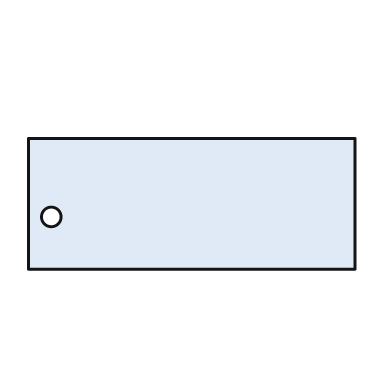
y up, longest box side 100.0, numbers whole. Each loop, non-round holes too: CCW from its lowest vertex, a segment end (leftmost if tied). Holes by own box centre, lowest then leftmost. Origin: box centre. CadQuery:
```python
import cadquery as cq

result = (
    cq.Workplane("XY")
    .moveTo(-50.0, -20.0)
    .lineTo(50.0, -20.0)
    .lineTo(50.0, 20.0)
    .lineTo(-50.0, 20.0)
    .close()
    .moveTo(-43.0, -4.0)
    .circle(3.0)
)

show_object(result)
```